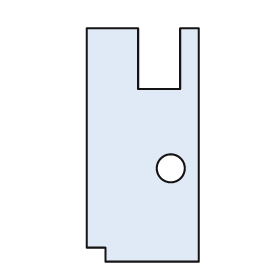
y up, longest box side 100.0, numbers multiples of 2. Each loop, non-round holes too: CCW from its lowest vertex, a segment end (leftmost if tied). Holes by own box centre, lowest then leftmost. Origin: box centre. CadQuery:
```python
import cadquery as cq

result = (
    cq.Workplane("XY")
    .moveTo(-16.0, -50.0)
    .lineTo(24.0, -50.0)
    .lineTo(24.0, 50.0)
    .lineTo(16.0, 50.0)
    .lineTo(16.0, 24.0)
    .lineTo(-2.0, 24.0)
    .lineTo(-2.0, 50.0)
    .lineTo(-24.0, 50.0)
    .lineTo(-24.0, -44.0)
    .lineTo(-16.0, -44.0)
    .close()
    .moveTo(12.0, -10.0)
    .circle(6.0)
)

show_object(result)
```